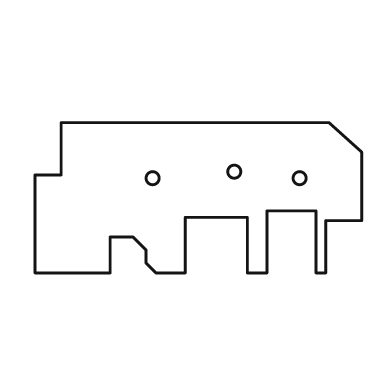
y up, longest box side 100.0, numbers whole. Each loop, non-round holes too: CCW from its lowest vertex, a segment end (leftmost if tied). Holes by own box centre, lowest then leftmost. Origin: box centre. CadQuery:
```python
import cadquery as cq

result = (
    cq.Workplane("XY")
    .moveTo(-50.0, -23.0)
    .lineTo(-27.0, -23.0)
    .lineTo(-27.0, -12.0)
    .lineTo(-20.0, -12.0)
    .lineTo(-16.0, -16.0)
    .lineTo(-16.0, -20.0)
    .lineTo(-13.0, -23.0)
    .lineTo(-4.0, -23.0)
    .lineTo(-4.0, -6.0)
    .lineTo(15.0, -6.0)
    .lineTo(15.0, -23.0)
    .lineTo(21.0, -23.0)
    .lineTo(21.0, -4.0)
    .lineTo(36.0, -4.0)
    .lineTo(36.0, -23.0)
    .lineTo(39.0, -23.0)
    .lineTo(39.0, -7.0)
    .lineTo(50.0, -7.0)
    .lineTo(50.0, 14.0)
    .lineTo(40.0, 23.0)
    .lineTo(-42.0, 23.0)
    .lineTo(-42.0, 7.0)
    .lineTo(-50.0, 7.0)
    .close()
    .moveTo(-14.0, 6.0)
    .circle(2.0)
    .moveTo(31.0, 6.0)
    .circle(2.0)
    .moveTo(11.0, 8.0)
    .circle(2.0)
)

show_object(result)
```